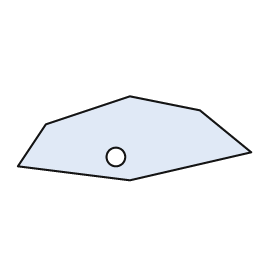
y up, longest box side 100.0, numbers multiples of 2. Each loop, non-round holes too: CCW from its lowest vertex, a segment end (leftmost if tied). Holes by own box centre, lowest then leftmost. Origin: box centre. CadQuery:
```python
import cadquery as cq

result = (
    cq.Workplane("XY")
    .moveTo(-2.0, -18.0)
    .lineTo(50.0, -6.0)
    .lineTo(28.0, 12.0)
    .lineTo(-2.0, 18.0)
    .lineTo(-38.0, 6.0)
    .lineTo(-50.0, -12.0)
    .close()
    .moveTo(-8.0, -8.0)
    .circle(4.0)
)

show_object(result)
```